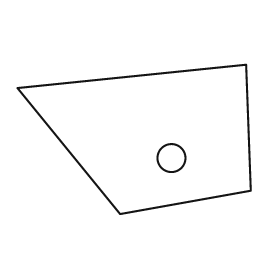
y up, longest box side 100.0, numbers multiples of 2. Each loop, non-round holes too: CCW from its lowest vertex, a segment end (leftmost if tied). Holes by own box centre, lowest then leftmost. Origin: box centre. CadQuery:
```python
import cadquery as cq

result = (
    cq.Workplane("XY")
    .moveTo(-6.0, -32.0)
    .lineTo(50.0, -22.0)
    .lineTo(48.0, 32.0)
    .lineTo(-50.0, 22.0)
    .close()
    .moveTo(16.0, -8.0)
    .circle(6.0)
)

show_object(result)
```